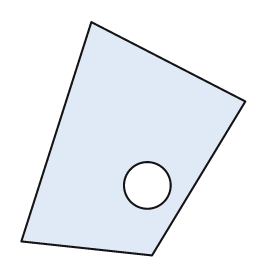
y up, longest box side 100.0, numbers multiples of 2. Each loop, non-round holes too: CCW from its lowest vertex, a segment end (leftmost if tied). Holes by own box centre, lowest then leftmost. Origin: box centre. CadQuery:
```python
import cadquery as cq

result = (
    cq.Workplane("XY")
    .moveTo(8.0, -50.0)
    .lineTo(48.0, 16.0)
    .lineTo(-18.0, 50.0)
    .lineTo(-48.0, -44.0)
    .close()
    .moveTo(6.0, -20.0)
    .circle(10.0)
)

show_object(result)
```